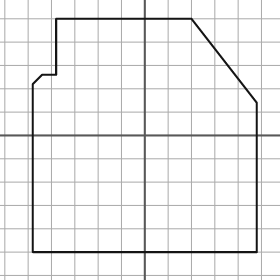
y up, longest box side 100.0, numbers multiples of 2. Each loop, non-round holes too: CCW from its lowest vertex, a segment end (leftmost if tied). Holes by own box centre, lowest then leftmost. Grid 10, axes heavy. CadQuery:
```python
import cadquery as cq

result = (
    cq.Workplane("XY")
    .moveTo(-48.0, -50.0)
    .lineTo(48.0, -50.0)
    .lineTo(48.0, 14.0)
    .lineTo(20.0, 50.0)
    .lineTo(-38.0, 50.0)
    .lineTo(-38.0, 26.0)
    .lineTo(-44.0, 26.0)
    .lineTo(-48.0, 22.0)
    .close()
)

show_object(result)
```